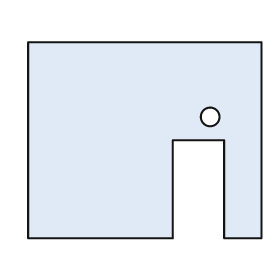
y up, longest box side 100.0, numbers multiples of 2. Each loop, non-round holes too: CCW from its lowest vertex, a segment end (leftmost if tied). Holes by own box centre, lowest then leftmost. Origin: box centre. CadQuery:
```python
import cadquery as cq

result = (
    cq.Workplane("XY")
    .moveTo(-50.0, -42.0)
    .lineTo(12.0, -42.0)
    .lineTo(12.0, 0.0)
    .lineTo(34.0, 0.0)
    .lineTo(34.0, -42.0)
    .lineTo(50.0, -42.0)
    .lineTo(50.0, 42.0)
    .lineTo(-50.0, 42.0)
    .close()
    .moveTo(28.0, 10.0)
    .circle(4.0)
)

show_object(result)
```